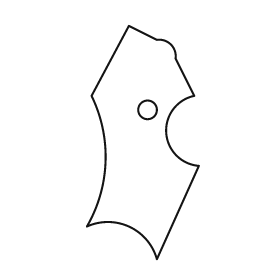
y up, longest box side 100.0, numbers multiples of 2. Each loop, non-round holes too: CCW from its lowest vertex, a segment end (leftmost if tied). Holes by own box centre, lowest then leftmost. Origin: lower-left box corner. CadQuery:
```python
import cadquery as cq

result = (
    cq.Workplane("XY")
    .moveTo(30.0, 0.0)
    .lineTo(48.0, 40.0)
    .threePointArc((34.0, 54.0), (46.0, 70.0))
    .lineTo(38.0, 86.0)
    .threePointArc((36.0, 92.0), (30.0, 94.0))
    .lineTo(18.0, 100.0)
    .lineTo(2.0, 70.0)
    .threePointArc((8.0, 42.0), (0.0, 14.0))
    .threePointArc((18.0, 14.0), (30.0, 0.0))
    .close()
    .moveTo(26.0, 64.0)
    .circle(4.0)
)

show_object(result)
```